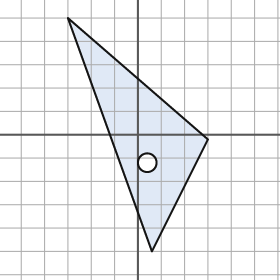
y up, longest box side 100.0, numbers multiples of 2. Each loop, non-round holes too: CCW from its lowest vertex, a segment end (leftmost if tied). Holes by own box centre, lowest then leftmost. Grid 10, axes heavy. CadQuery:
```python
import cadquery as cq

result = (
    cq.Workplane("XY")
    .moveTo(6.0, -50.0)
    .lineTo(30.0, -2.0)
    .lineTo(-30.0, 50.0)
    .close()
    .moveTo(4.0, -12.0)
    .circle(4.0)
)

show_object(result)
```